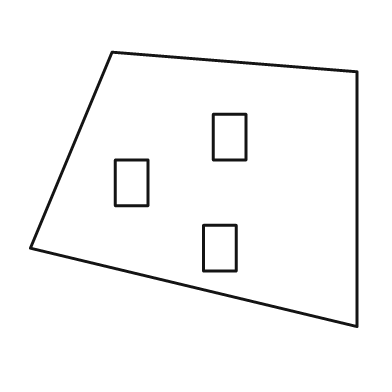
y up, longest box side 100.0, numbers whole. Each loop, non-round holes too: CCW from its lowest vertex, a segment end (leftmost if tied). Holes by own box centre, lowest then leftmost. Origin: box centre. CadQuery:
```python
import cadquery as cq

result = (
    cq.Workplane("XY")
    .moveTo(50.0, -42.0)
    .lineTo(50.0, 36.0)
    .lineTo(-25.0, 42.0)
    .lineTo(-50.0, -18.0)
    .close()
    .moveTo(3.0, -25.0)
    .lineTo(13.0, -25.0)
    .lineTo(13.0, -11.0)
    .lineTo(3.0, -11.0)
    .close()
    .moveTo(-24.0, -5.0)
    .lineTo(-14.0, -5.0)
    .lineTo(-14.0, 9.0)
    .lineTo(-24.0, 9.0)
    .close()
    .moveTo(6.0, 9.0)
    .lineTo(16.0, 9.0)
    .lineTo(16.0, 23.0)
    .lineTo(6.0, 23.0)
    .close()
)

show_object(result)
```